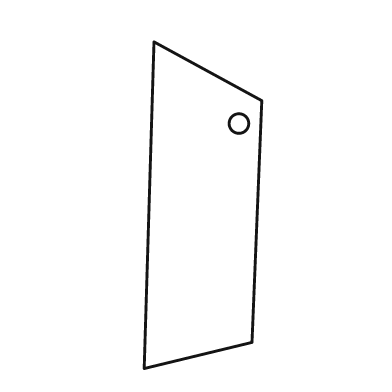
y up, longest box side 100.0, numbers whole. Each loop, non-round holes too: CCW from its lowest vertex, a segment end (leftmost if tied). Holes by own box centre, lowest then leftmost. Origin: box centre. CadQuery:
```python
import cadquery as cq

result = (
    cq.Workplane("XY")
    .moveTo(-18.0, -50.0)
    .lineTo(15.0, -42.0)
    .lineTo(18.0, 32.0)
    .lineTo(-15.0, 50.0)
    .close()
    .moveTo(11.0, 25.0)
    .circle(3.0)
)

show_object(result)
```